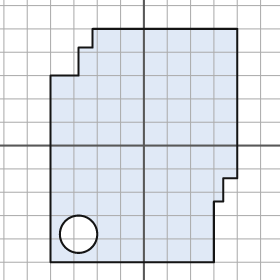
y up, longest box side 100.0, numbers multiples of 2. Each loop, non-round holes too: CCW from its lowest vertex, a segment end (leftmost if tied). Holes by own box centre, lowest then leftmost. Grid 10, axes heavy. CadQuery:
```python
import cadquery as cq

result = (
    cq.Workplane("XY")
    .moveTo(-40.0, -50.0)
    .lineTo(30.0, -50.0)
    .lineTo(30.0, -24.0)
    .lineTo(34.0, -24.0)
    .lineTo(34.0, -14.0)
    .lineTo(40.0, -14.0)
    .lineTo(40.0, 50.0)
    .lineTo(-22.0, 50.0)
    .lineTo(-22.0, 42.0)
    .lineTo(-28.0, 42.0)
    .lineTo(-28.0, 30.0)
    .lineTo(-40.0, 30.0)
    .close()
    .moveTo(-28.0, -38.0)
    .circle(8.0)
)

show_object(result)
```